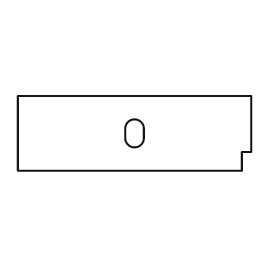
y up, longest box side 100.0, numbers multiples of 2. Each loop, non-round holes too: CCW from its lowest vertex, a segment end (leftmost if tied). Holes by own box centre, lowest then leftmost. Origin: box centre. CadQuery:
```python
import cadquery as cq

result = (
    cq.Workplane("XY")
    .moveTo(-50.0, -16.0)
    .lineTo(46.0, -16.0)
    .lineTo(46.0, -8.0)
    .lineTo(50.0, -8.0)
    .lineTo(50.0, 16.0)
    .lineTo(-50.0, 16.0)
    .close()
    .moveTo(-4.0, -2.0)
    .threePointArc((0.0, -6.0), (4.0, -2.0))
    .lineTo(4.0, 2.0)
    .threePointArc((0.0, 6.0), (-4.0, 2.0))
    .close()
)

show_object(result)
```